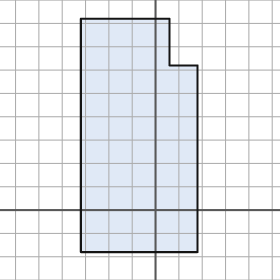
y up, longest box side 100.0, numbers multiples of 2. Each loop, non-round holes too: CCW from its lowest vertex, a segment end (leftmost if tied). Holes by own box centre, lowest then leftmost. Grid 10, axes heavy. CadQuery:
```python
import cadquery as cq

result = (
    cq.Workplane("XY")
    .moveTo(-32.0, -18.0)
    .lineTo(18.0, -18.0)
    .lineTo(18.0, 62.0)
    .lineTo(6.0, 62.0)
    .lineTo(6.0, 82.0)
    .lineTo(-32.0, 82.0)
    .close()
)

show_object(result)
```